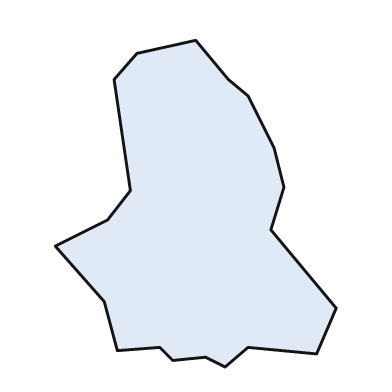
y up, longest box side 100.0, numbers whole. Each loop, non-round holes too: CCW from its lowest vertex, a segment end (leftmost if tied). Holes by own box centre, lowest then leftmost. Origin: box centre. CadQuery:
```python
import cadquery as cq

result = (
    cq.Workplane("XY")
    .moveTo(9.0, -50.0)
    .lineTo(16.0, -44.0)
    .lineTo(37.0, -46.0)
    .lineTo(43.0, -32.0)
    .lineTo(23.0, -8.0)
    .lineTo(27.0, 5.0)
    .lineTo(24.0, 17.0)
    .lineTo(16.0, 33.0)
    .lineTo(10.0, 38.0)
    .lineTo(0.0, 50.0)
    .lineTo(-18.0, 46.0)
    .lineTo(-25.0, 38.0)
    .lineTo(-20.0, 4.0)
    .lineTo(-27.0, -5.0)
    .lineTo(-43.0, -13.0)
    .lineTo(-28.0, -30.0)
    .lineTo(-24.0, -45.0)
    .lineTo(-11.0, -44.0)
    .lineTo(-7.0, -48.0)
    .lineTo(3.0, -47.0)
    .close()
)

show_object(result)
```